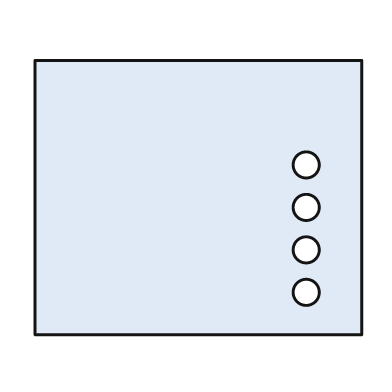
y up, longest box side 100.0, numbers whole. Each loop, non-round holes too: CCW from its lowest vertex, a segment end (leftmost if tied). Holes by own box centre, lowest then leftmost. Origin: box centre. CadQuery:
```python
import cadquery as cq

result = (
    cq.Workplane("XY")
    .moveTo(-50.0, -42.0)
    .lineTo(50.0, -42.0)
    .lineTo(50.0, 42.0)
    .lineTo(-50.0, 42.0)
    .close()
    .moveTo(33.0, -29.0)
    .circle(4.0)
    .moveTo(33.0, -16.0)
    .circle(4.0)
    .moveTo(33.0, -3.0)
    .circle(4.0)
    .moveTo(33.0, 10.0)
    .circle(4.0)
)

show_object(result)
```